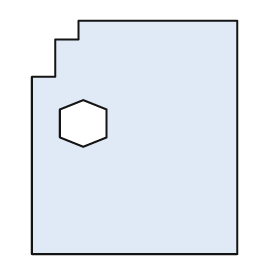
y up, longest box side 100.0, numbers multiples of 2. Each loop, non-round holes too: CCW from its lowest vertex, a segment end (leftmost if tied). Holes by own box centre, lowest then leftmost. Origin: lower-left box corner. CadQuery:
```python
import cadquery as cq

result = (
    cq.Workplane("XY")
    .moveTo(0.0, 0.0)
    .lineTo(88.0, 0.0)
    .lineTo(88.0, 100.0)
    .lineTo(20.0, 100.0)
    .lineTo(20.0, 92.0)
    .lineTo(10.0, 92.0)
    .lineTo(10.0, 76.0)
    .lineTo(0.0, 76.0)
    .close()
    .moveTo(22.0, 46.0)
    .lineTo(32.0, 50.0)
    .lineTo(32.0, 62.0)
    .lineTo(22.0, 66.0)
    .lineTo(12.0, 62.0)
    .lineTo(12.0, 50.0)
    .close()
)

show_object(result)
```